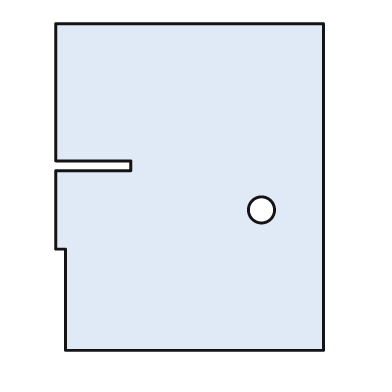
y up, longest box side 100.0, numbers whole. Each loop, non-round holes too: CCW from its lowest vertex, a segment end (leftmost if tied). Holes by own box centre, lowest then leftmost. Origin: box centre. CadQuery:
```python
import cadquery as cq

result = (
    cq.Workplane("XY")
    .moveTo(-38.0, -50.0)
    .lineTo(41.0, -50.0)
    .lineTo(41.0, 50.0)
    .lineTo(-41.0, 50.0)
    .lineTo(-41.0, 8.0)
    .lineTo(-18.0, 8.0)
    .lineTo(-18.0, 5.0)
    .lineTo(-41.0, 5.0)
    .lineTo(-41.0, -19.0)
    .lineTo(-38.0, -19.0)
    .close()
    .moveTo(22.0, -7.0)
    .circle(4.0)
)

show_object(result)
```